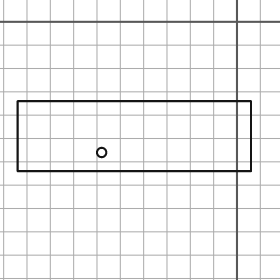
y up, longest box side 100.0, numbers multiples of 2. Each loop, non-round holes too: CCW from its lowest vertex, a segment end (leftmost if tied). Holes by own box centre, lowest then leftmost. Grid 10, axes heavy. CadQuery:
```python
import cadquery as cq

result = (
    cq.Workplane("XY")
    .moveTo(-94.0, -64.0)
    .lineTo(6.0, -64.0)
    .lineTo(6.0, -34.0)
    .lineTo(-94.0, -34.0)
    .close()
    .moveTo(-58.0, -56.0)
    .circle(2.0)
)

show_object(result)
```